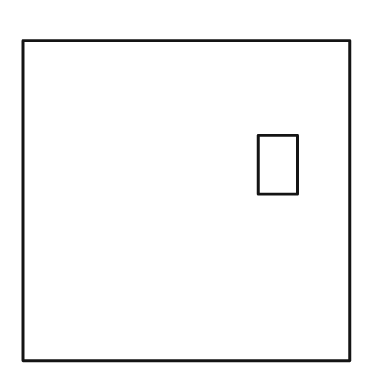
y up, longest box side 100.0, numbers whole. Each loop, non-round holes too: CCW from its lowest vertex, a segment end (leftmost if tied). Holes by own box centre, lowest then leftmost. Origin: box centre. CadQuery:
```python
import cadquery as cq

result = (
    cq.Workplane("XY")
    .moveTo(-50.0, -49.0)
    .lineTo(50.0, -49.0)
    .lineTo(50.0, 49.0)
    .lineTo(-50.0, 49.0)
    .close()
    .moveTo(22.0, 2.0)
    .lineTo(34.0, 2.0)
    .lineTo(34.0, 20.0)
    .lineTo(22.0, 20.0)
    .close()
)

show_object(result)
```